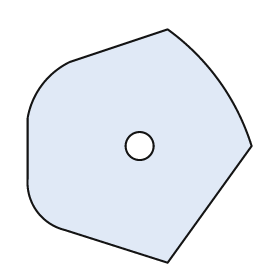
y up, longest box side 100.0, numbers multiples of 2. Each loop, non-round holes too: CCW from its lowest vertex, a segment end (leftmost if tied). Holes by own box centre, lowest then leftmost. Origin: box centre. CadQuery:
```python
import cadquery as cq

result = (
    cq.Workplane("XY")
    .moveTo(12.0, -50.0)
    .lineTo(48.0, 0.0)
    .threePointArc((34.0, 28.0), (12.0, 50.0))
    .lineTo(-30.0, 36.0)
    .threePointArc((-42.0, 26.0), (-48.0, 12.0))
    .lineTo(-48.0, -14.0)
    .threePointArc((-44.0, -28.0), (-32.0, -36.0))
    .close()
    .moveTo(0.0, 0.0)
    .circle(6.0)
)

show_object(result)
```